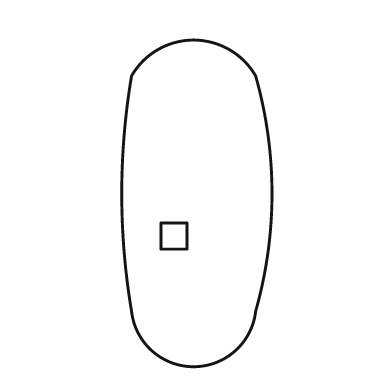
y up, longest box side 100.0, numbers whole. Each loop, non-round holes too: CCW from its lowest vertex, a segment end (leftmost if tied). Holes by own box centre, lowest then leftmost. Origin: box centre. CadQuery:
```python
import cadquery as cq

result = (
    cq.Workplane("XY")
    .moveTo(-20.0, -33.0)
    .threePointArc((-1.0, -50.0), (18.0, -33.0))
    .threePointArc((23.0, 3.0), (18.0, 39.0))
    .threePointArc((-1.0, 50.0), (-20.0, 39.0))
    .threePointArc((-23.0, 3.0), (-20.0, -33.0))
    .close()
    .moveTo(-11.0, -14.0)
    .lineTo(-3.0, -14.0)
    .lineTo(-3.0, -6.0)
    .lineTo(-11.0, -6.0)
    .close()
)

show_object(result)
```